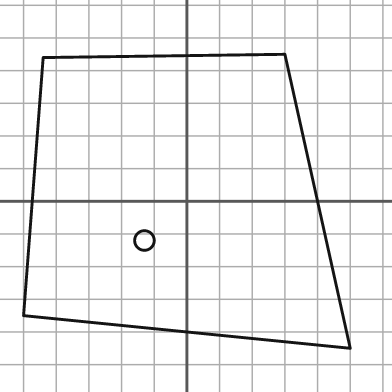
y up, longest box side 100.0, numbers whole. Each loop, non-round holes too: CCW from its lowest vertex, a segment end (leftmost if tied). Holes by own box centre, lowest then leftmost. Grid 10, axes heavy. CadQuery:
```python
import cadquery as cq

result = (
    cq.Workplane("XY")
    .moveTo(50.0, -45.0)
    .lineTo(30.0, 45.0)
    .lineTo(-44.0, 44.0)
    .lineTo(-50.0, -35.0)
    .close()
    .moveTo(-13.0, -12.0)
    .circle(3.0)
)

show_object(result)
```